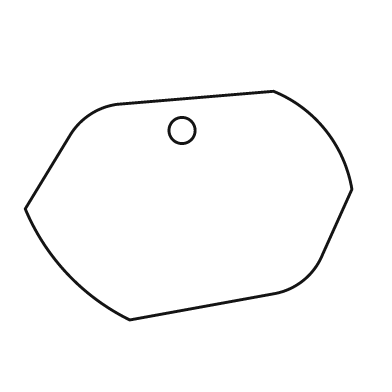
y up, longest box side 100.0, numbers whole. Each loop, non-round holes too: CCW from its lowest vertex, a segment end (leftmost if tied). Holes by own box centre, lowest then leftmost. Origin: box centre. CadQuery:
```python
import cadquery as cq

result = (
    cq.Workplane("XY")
    .moveTo(-18.0, -35.0)
    .lineTo(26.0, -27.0)
    .threePointArc((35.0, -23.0), (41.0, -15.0))
    .lineTo(50.0, 5.0)
    .threePointArc((42.0, 23.0), (26.0, 35.0))
    .lineTo(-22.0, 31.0)
    .threePointArc((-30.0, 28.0), (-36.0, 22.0))
    .lineTo(-50.0, -1.0)
    .threePointArc((-37.0, -21.0), (-18.0, -35.0))
    .close()
    .moveTo(-2.0, 23.0)
    .circle(4.0)
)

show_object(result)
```